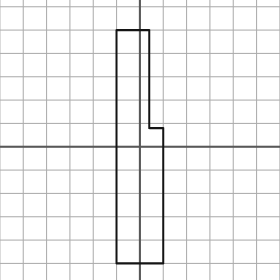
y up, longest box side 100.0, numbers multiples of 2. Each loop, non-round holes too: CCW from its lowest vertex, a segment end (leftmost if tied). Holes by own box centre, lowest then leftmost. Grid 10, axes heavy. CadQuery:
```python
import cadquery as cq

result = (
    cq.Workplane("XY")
    .moveTo(-10.0, -50.0)
    .lineTo(10.0, -50.0)
    .lineTo(10.0, 8.0)
    .lineTo(4.0, 8.0)
    .lineTo(4.0, 50.0)
    .lineTo(-10.0, 50.0)
    .close()
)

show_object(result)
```